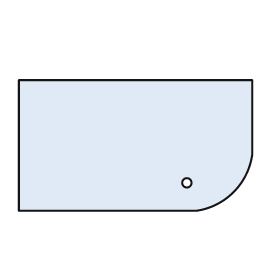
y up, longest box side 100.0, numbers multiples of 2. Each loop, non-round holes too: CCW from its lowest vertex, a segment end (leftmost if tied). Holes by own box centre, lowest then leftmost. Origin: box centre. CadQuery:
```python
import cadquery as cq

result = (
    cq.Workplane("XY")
    .moveTo(-50.0, -28.0)
    .lineTo(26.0, -28.0)
    .threePointArc((42.0, -20.0), (50.0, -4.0))
    .lineTo(50.0, 28.0)
    .lineTo(-50.0, 28.0)
    .close()
    .moveTo(22.0, -16.0)
    .circle(2.0)
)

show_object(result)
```